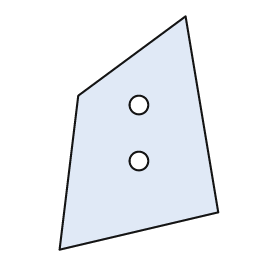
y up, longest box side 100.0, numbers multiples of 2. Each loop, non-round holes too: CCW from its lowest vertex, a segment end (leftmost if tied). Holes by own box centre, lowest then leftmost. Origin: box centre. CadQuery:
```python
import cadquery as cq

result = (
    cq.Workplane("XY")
    .moveTo(-34.0, -50.0)
    .lineTo(34.0, -34.0)
    .lineTo(20.0, 50.0)
    .lineTo(-26.0, 16.0)
    .close()
    .moveTo(0.0, -12.0)
    .circle(4.0)
    .moveTo(0.0, 12.0)
    .circle(4.0)
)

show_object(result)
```